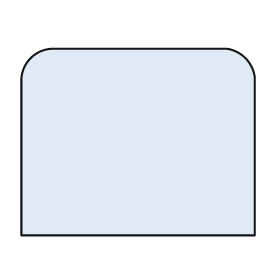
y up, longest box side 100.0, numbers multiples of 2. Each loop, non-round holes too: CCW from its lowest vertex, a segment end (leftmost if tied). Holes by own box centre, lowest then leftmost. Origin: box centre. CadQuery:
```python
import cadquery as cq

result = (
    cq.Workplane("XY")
    .moveTo(-50.0, -40.0)
    .lineTo(50.0, -40.0)
    .lineTo(50.0, 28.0)
    .threePointArc((46.0, 36.0), (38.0, 40.0))
    .lineTo(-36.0, 40.0)
    .threePointArc((-46.0, 36.0), (-50.0, 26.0))
    .close()
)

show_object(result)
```